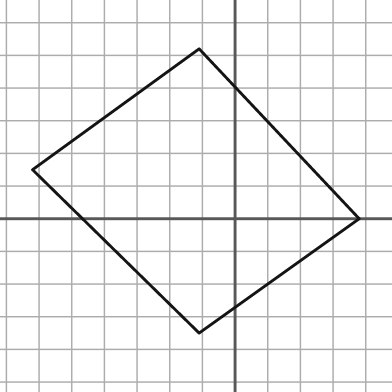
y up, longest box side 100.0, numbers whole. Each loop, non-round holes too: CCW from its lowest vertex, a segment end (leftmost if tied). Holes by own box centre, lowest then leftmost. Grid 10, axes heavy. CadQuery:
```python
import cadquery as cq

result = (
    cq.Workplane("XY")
    .moveTo(-11.0, -35.0)
    .lineTo(38.0, 0.0)
    .lineTo(-11.0, 52.0)
    .lineTo(-62.0, 15.0)
    .close()
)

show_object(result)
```